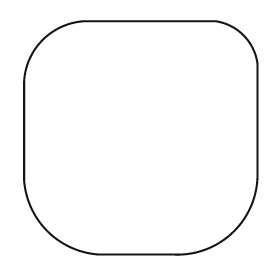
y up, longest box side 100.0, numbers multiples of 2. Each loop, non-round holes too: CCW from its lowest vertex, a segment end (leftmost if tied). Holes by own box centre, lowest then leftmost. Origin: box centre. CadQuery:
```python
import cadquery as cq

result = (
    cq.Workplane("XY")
    .moveTo(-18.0, -50.0)
    .lineTo(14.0, -50.0)
    .threePointArc((40.0, -40.0), (50.0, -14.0))
    .lineTo(50.0, 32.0)
    .threePointArc((44.0, 44.0), (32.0, 50.0))
    .lineTo(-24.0, 50.0)
    .threePointArc((-42.0, 42.0), (-50.0, 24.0))
    .lineTo(-50.0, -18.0)
    .threePointArc((-40.0, -40.0), (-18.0, -50.0))
    .close()
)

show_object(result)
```